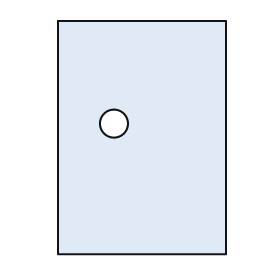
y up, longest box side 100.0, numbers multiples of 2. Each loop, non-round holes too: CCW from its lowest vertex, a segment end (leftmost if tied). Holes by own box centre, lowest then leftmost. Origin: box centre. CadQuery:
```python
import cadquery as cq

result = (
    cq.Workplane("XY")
    .moveTo(-36.0, -50.0)
    .lineTo(36.0, -50.0)
    .lineTo(36.0, 50.0)
    .lineTo(-36.0, 50.0)
    .close()
    .moveTo(-12.0, 6.0)
    .circle(6.0)
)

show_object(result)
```